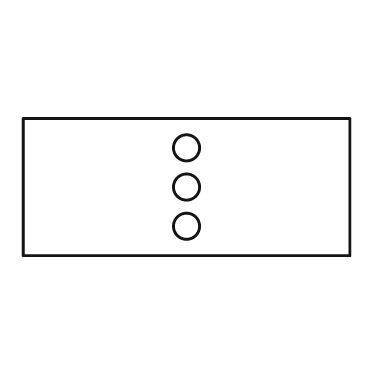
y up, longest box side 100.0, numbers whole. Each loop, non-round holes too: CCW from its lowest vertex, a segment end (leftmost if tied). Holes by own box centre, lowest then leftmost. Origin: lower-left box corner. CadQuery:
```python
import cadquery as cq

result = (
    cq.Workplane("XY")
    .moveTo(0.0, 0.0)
    .lineTo(100.0, 0.0)
    .lineTo(100.0, 42.0)
    .lineTo(0.0, 42.0)
    .close()
    .moveTo(50.0, 9.0)
    .circle(4.0)
    .moveTo(50.0, 21.0)
    .circle(4.0)
    .moveTo(50.0, 33.0)
    .circle(4.0)
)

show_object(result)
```